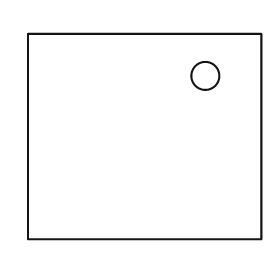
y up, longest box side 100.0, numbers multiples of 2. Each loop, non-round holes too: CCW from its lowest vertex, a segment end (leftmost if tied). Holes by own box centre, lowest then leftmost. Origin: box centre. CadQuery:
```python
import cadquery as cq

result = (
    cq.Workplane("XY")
    .moveTo(-50.0, -44.0)
    .lineTo(50.0, -44.0)
    .lineTo(50.0, 44.0)
    .lineTo(-50.0, 44.0)
    .close()
    .moveTo(26.0, 26.0)
    .circle(6.0)
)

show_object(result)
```